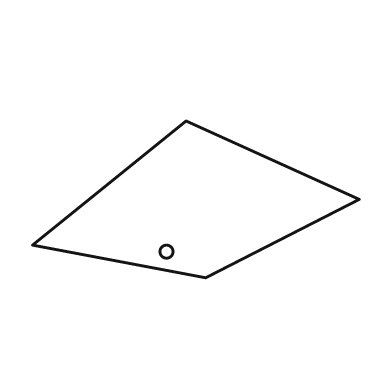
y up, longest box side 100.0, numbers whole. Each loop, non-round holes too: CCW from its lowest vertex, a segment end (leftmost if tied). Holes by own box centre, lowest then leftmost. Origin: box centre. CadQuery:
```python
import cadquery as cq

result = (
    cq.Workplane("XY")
    .moveTo(3.0, -24.0)
    .lineTo(50.0, 0.0)
    .lineTo(-3.0, 24.0)
    .lineTo(-50.0, -14.0)
    .close()
    .moveTo(-9.0, -16.0)
    .circle(2.0)
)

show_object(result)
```